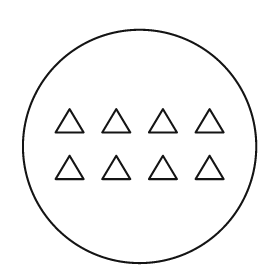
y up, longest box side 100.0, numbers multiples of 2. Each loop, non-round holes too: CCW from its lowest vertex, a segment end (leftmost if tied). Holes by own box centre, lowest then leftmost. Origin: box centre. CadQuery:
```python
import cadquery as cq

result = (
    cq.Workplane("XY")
    .moveTo(0.0, 0.0)
    .circle(50.0)
    .moveTo(-36.0, -14.0)
    .lineTo(-24.0, -14.0)
    .lineTo(-30.0, -4.0)
    .close()
    .moveTo(-16.0, -14.0)
    .lineTo(-4.0, -14.0)
    .lineTo(-10.0, -4.0)
    .close()
    .moveTo(4.0, -14.0)
    .lineTo(16.0, -14.0)
    .lineTo(10.0, -4.0)
    .close()
    .moveTo(24.0, -14.0)
    .lineTo(36.0, -14.0)
    .lineTo(30.0, -4.0)
    .close()
    .moveTo(-36.0, 6.0)
    .lineTo(-24.0, 6.0)
    .lineTo(-30.0, 16.0)
    .close()
    .moveTo(-16.0, 6.0)
    .lineTo(-4.0, 6.0)
    .lineTo(-10.0, 16.0)
    .close()
    .moveTo(4.0, 6.0)
    .lineTo(16.0, 6.0)
    .lineTo(10.0, 16.0)
    .close()
    .moveTo(24.0, 6.0)
    .lineTo(36.0, 6.0)
    .lineTo(30.0, 16.0)
    .close()
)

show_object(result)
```